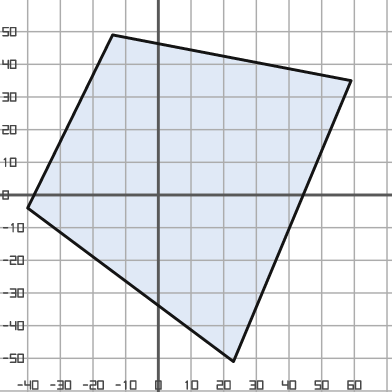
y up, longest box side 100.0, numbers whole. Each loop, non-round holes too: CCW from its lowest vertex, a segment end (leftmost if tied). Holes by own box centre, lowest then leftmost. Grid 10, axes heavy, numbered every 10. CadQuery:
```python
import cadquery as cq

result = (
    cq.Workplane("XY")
    .moveTo(23.0, -51.0)
    .lineTo(59.0, 35.0)
    .lineTo(-14.0, 49.0)
    .lineTo(-40.0, -4.0)
    .close()
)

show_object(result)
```